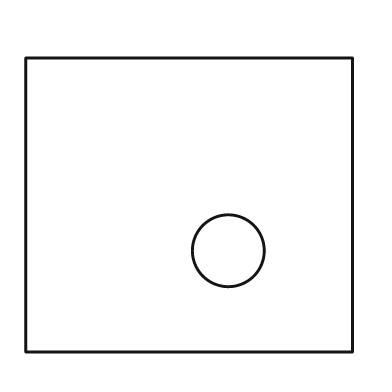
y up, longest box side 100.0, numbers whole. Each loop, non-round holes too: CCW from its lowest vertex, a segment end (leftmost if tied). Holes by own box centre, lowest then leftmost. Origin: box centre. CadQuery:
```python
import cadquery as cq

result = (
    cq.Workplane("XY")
    .moveTo(-50.0, -45.0)
    .lineTo(50.0, -45.0)
    .lineTo(50.0, 45.0)
    .lineTo(-50.0, 45.0)
    .close()
    .moveTo(12.0, -14.0)
    .circle(11.0)
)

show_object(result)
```